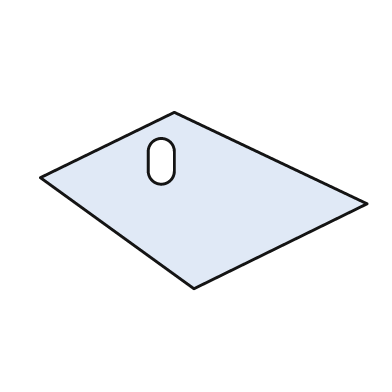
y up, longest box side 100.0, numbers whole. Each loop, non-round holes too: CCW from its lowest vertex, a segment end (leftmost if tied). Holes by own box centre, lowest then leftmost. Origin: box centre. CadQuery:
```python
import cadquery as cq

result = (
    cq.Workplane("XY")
    .moveTo(-3.0, -27.0)
    .lineTo(50.0, -1.0)
    .lineTo(-9.0, 27.0)
    .lineTo(-50.0, 7.0)
    .close()
    .moveTo(-17.0, 9.0)
    .threePointArc((-13.0, 5.0), (-9.0, 9.0))
    .lineTo(-9.0, 15.0)
    .threePointArc((-13.0, 19.0), (-17.0, 15.0))
    .close()
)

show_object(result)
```